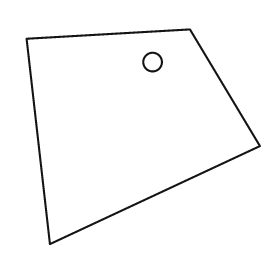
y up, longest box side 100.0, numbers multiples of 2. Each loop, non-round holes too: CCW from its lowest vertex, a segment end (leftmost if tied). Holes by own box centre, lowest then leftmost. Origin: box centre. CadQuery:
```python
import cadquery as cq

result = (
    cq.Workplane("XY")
    .moveTo(-40.0, -46.0)
    .lineTo(50.0, -4.0)
    .lineTo(20.0, 46.0)
    .lineTo(-50.0, 42.0)
    .close()
    .moveTo(4.0, 32.0)
    .circle(4.0)
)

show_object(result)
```